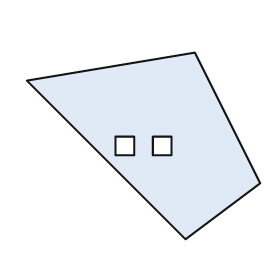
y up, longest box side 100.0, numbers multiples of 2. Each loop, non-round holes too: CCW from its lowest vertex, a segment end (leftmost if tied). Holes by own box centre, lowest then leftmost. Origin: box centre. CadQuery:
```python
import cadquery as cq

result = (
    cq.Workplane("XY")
    .moveTo(18.0, -40.0)
    .lineTo(50.0, -16.0)
    .lineTo(22.0, 40.0)
    .lineTo(-50.0, 28.0)
    .close()
    .moveTo(-12.0, -4.0)
    .lineTo(-4.0, -4.0)
    .lineTo(-4.0, 4.0)
    .lineTo(-12.0, 4.0)
    .close()
    .moveTo(4.0, -4.0)
    .lineTo(12.0, -4.0)
    .lineTo(12.0, 4.0)
    .lineTo(4.0, 4.0)
    .close()
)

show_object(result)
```